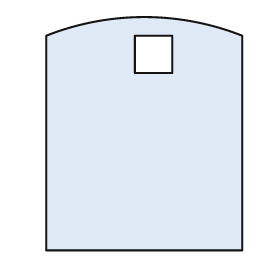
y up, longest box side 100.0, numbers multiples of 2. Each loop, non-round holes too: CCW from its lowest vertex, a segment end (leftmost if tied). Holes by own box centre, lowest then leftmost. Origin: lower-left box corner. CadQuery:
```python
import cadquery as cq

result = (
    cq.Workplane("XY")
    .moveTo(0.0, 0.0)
    .lineTo(84.0, 0.0)
    .lineTo(84.0, 92.0)
    .threePointArc((42.0, 100.0), (0.0, 92.0))
    .close()
    .moveTo(38.0, 76.0)
    .lineTo(54.0, 76.0)
    .lineTo(54.0, 92.0)
    .lineTo(38.0, 92.0)
    .close()
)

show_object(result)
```